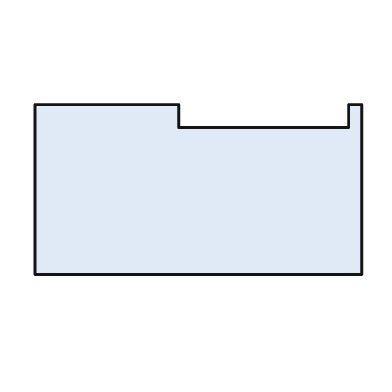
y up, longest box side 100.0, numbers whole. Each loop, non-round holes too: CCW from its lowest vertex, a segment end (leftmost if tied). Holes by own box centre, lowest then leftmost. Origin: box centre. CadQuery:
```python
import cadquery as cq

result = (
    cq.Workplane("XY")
    .moveTo(-50.0, -26.0)
    .lineTo(50.0, -26.0)
    .lineTo(50.0, 26.0)
    .lineTo(46.0, 26.0)
    .lineTo(46.0, 19.0)
    .lineTo(-6.0, 19.0)
    .lineTo(-6.0, 26.0)
    .lineTo(-50.0, 26.0)
    .close()
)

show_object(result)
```